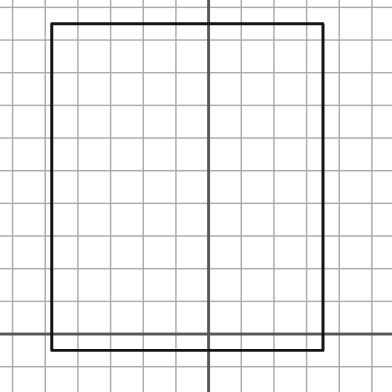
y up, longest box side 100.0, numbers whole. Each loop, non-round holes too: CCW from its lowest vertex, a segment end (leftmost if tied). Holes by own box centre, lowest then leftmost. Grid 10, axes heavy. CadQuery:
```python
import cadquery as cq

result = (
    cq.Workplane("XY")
    .moveTo(-48.0, -5.0)
    .lineTo(35.0, -5.0)
    .lineTo(35.0, 95.0)
    .lineTo(-48.0, 95.0)
    .close()
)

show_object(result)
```